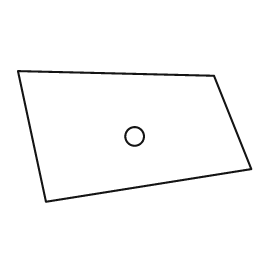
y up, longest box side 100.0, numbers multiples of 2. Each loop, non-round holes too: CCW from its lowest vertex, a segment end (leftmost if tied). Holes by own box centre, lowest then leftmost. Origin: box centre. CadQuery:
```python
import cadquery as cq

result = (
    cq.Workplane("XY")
    .moveTo(-38.0, -28.0)
    .lineTo(50.0, -14.0)
    .lineTo(34.0, 26.0)
    .lineTo(-50.0, 28.0)
    .close()
    .moveTo(0.0, 0.0)
    .circle(4.0)
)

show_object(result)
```